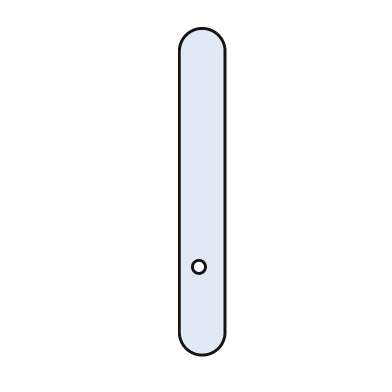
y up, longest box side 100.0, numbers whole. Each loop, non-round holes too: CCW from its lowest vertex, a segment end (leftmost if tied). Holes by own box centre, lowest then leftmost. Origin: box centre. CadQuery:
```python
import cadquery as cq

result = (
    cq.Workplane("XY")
    .moveTo(-7.0, -43.0)
    .threePointArc((0.0, -50.0), (7.0, -43.0))
    .lineTo(7.0, 43.0)
    .threePointArc((0.0, 50.0), (-7.0, 43.0))
    .close()
    .moveTo(-1.0, -23.0)
    .circle(2.0)
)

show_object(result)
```